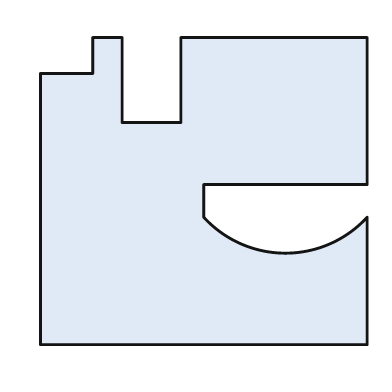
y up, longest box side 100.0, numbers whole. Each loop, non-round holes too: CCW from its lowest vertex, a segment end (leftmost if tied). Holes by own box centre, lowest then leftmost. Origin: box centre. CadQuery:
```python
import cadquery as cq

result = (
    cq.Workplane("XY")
    .moveTo(-50.0, -47.0)
    .lineTo(50.0, -47.0)
    .lineTo(50.0, -8.0)
    .threePointArc((25.0, -19.0), (0.0, -8.0))
    .lineTo(0.0, 2.0)
    .lineTo(50.0, 2.0)
    .lineTo(50.0, 47.0)
    .lineTo(-7.0, 47.0)
    .lineTo(-7.0, 21.0)
    .lineTo(-25.0, 21.0)
    .lineTo(-25.0, 47.0)
    .lineTo(-34.0, 47.0)
    .lineTo(-34.0, 36.0)
    .lineTo(-50.0, 36.0)
    .close()
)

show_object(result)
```